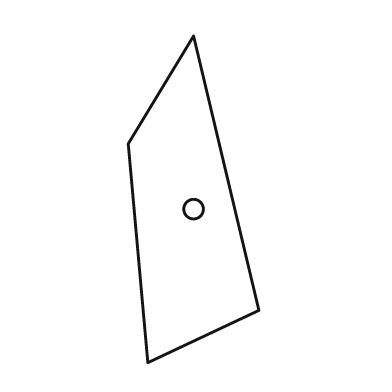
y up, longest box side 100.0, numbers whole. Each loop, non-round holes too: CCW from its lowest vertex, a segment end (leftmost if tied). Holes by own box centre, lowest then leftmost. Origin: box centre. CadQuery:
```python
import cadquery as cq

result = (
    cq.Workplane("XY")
    .moveTo(-14.0, -50.0)
    .lineTo(20.0, -34.0)
    .lineTo(0.0, 50.0)
    .lineTo(-20.0, 17.0)
    .close()
    .moveTo(0.0, -3.0)
    .circle(3.0)
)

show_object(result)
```